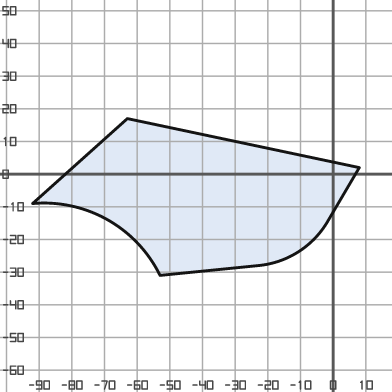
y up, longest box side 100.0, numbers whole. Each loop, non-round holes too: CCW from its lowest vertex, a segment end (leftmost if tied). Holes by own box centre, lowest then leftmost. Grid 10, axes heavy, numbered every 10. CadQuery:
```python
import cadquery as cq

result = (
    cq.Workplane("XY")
    .moveTo(-53.0, -31.0)
    .lineTo(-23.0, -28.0)
    .threePointArc((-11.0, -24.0), (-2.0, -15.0))
    .lineTo(8.0, 2.0)
    .lineTo(-63.0, 17.0)
    .lineTo(-92.0, -9.0)
    .threePointArc((-69.0, -14.0), (-53.0, -31.0))
    .close()
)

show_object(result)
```